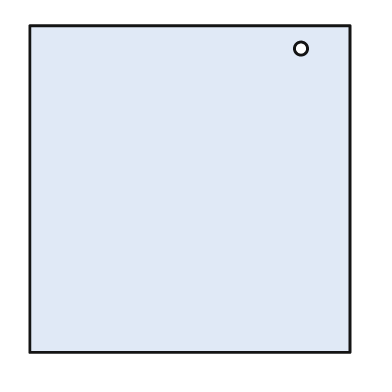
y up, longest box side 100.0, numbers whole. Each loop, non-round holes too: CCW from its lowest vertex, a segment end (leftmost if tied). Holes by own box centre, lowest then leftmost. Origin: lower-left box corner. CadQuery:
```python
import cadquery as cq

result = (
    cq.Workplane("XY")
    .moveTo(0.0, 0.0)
    .lineTo(98.0, 0.0)
    .lineTo(98.0, 100.0)
    .lineTo(0.0, 100.0)
    .close()
    .moveTo(83.0, 93.0)
    .circle(2.0)
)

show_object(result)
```